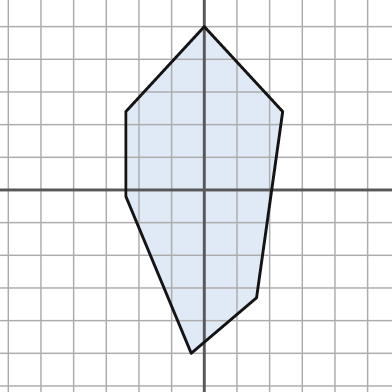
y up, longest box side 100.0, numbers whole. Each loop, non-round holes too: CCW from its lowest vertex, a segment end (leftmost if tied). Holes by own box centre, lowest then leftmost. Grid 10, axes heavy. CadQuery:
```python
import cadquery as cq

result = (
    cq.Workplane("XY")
    .moveTo(-4.0, -50.0)
    .lineTo(16.0, -33.0)
    .lineTo(24.0, 24.0)
    .lineTo(0.0, 50.0)
    .lineTo(-24.0, 24.0)
    .lineTo(-24.0, -2.0)
    .close()
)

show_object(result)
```